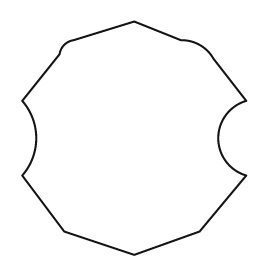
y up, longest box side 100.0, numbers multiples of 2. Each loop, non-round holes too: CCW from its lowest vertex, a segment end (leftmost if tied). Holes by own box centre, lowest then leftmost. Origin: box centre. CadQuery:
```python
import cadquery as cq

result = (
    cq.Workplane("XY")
    .moveTo(0.0, -50.0)
    .lineTo(28.0, -40.0)
    .lineTo(48.0, -16.0)
    .threePointArc((36.0, 0.0), (48.0, 16.0))
    .lineTo(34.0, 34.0)
    .threePointArc((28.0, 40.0), (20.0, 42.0))
    .lineTo(0.0, 50.0)
    .lineTo(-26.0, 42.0)
    .threePointArc((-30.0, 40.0), (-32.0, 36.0))
    .lineTo(-48.0, 16.0)
    .threePointArc((-42.0, 0.0), (-48.0, -16.0))
    .lineTo(-30.0, -40.0)
    .close()
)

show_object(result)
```